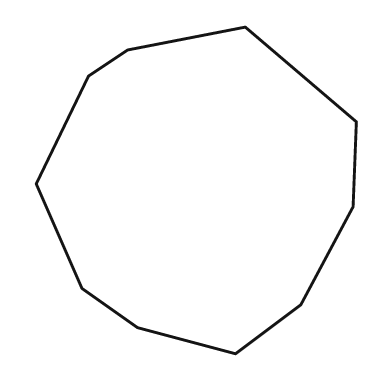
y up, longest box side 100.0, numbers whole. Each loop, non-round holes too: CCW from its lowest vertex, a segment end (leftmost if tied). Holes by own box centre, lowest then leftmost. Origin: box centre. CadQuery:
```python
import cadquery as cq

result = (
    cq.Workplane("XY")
    .moveTo(12.0, -50.0)
    .lineTo(32.0, -35.0)
    .lineTo(48.0, -5.0)
    .lineTo(49.0, 21.0)
    .lineTo(15.0, 50.0)
    .lineTo(-21.0, 43.0)
    .lineTo(-33.0, 35.0)
    .lineTo(-49.0, 2.0)
    .lineTo(-35.0, -30.0)
    .lineTo(-18.0, -42.0)
    .close()
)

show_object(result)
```